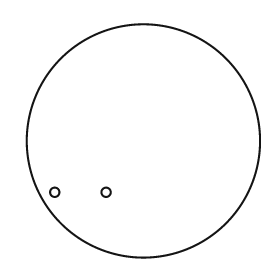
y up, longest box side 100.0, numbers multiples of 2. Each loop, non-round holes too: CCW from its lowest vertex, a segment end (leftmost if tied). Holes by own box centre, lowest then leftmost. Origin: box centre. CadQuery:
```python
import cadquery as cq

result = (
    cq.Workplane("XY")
    .moveTo(0.0, 0.0)
    .circle(50.0)
    .moveTo(-38.0, -22.0)
    .circle(2.0)
    .moveTo(-16.0, -22.0)
    .circle(2.0)
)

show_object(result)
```